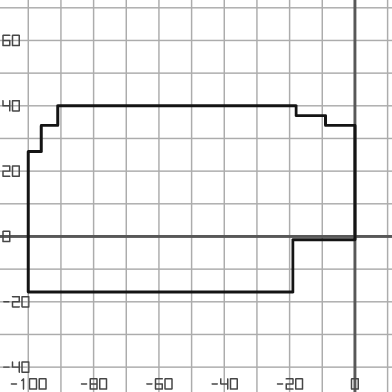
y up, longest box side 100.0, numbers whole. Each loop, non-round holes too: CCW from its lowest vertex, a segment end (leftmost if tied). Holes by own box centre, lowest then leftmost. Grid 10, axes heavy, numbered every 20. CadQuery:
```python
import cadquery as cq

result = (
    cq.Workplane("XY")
    .moveTo(-100.0, -17.0)
    .lineTo(-19.0, -17.0)
    .lineTo(-19.0, -1.0)
    .lineTo(0.0, -1.0)
    .lineTo(0.0, 34.0)
    .lineTo(-9.0, 34.0)
    .lineTo(-9.0, 37.0)
    .lineTo(-18.0, 37.0)
    .lineTo(-18.0, 40.0)
    .lineTo(-91.0, 40.0)
    .lineTo(-91.0, 34.0)
    .lineTo(-96.0, 34.0)
    .lineTo(-96.0, 26.0)
    .lineTo(-100.0, 26.0)
    .close()
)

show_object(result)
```